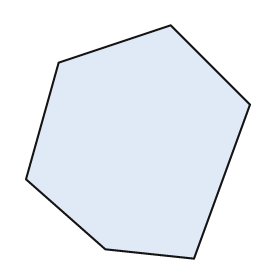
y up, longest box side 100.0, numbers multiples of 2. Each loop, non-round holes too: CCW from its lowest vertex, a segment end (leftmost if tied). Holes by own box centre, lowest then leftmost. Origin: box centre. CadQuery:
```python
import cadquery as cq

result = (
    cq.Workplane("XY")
    .moveTo(24.0, -50.0)
    .lineTo(48.0, 16.0)
    .lineTo(14.0, 50.0)
    .lineTo(-34.0, 34.0)
    .lineTo(-48.0, -16.0)
    .lineTo(-14.0, -46.0)
    .close()
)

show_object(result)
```